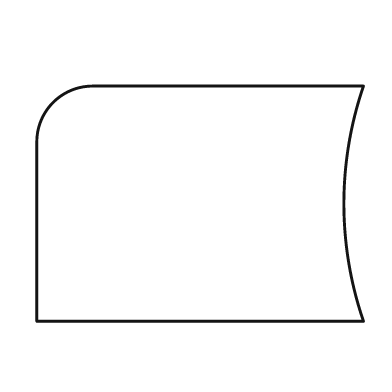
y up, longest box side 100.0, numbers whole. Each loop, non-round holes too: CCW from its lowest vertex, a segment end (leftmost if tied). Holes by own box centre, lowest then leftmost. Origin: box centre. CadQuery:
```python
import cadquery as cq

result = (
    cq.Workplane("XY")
    .moveTo(-50.0, -36.0)
    .lineTo(50.0, -36.0)
    .threePointArc((44.0, 0.0), (50.0, 36.0))
    .lineTo(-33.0, 36.0)
    .threePointArc((-45.0, 31.0), (-50.0, 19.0))
    .close()
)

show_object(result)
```